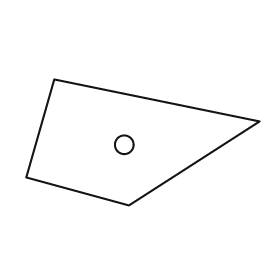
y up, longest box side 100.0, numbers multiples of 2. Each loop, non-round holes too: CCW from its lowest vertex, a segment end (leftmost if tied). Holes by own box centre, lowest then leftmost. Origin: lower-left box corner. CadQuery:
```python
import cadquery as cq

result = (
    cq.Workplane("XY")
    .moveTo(44.0, 0.0)
    .lineTo(100.0, 36.0)
    .lineTo(12.0, 54.0)
    .lineTo(0.0, 12.0)
    .close()
    .moveTo(42.0, 26.0)
    .circle(4.0)
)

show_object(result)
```